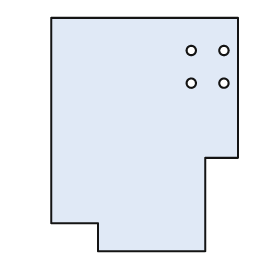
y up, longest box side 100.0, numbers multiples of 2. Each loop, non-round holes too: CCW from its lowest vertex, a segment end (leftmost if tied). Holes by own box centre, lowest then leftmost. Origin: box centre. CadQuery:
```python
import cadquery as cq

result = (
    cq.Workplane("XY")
    .moveTo(-20.0, -50.0)
    .lineTo(26.0, -50.0)
    .lineTo(26.0, -10.0)
    .lineTo(40.0, -10.0)
    .lineTo(40.0, 50.0)
    .lineTo(-40.0, 50.0)
    .lineTo(-40.0, -38.0)
    .lineTo(-20.0, -38.0)
    .close()
    .moveTo(20.0, 22.0)
    .circle(2.0)
    .moveTo(34.0, 22.0)
    .circle(2.0)
    .moveTo(20.0, 36.0)
    .circle(2.0)
    .moveTo(34.0, 36.0)
    .circle(2.0)
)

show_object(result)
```